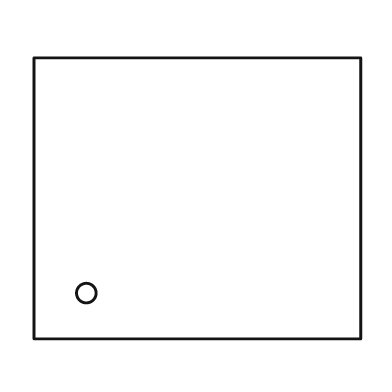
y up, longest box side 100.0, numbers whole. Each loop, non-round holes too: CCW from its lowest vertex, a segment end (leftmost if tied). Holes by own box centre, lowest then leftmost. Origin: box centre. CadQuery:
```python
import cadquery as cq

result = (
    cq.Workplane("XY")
    .moveTo(-50.0, -43.0)
    .lineTo(50.0, -43.0)
    .lineTo(50.0, 43.0)
    .lineTo(-50.0, 43.0)
    .close()
    .moveTo(-34.0, -29.0)
    .circle(3.0)
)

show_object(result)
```